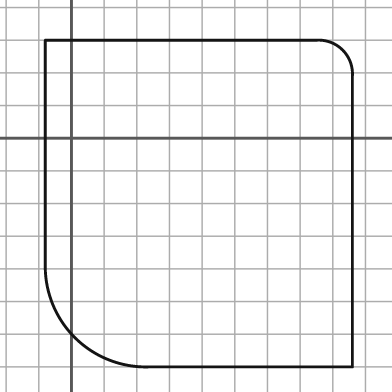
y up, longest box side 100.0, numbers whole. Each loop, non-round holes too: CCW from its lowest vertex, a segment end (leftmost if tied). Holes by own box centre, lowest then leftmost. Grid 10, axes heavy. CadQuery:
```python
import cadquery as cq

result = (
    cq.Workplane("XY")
    .moveTo(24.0, -70.0)
    .lineTo(86.0, -70.0)
    .lineTo(86.0, 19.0)
    .threePointArc((83.0, 27.0), (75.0, 30.0))
    .lineTo(-8.0, 30.0)
    .lineTo(-8.0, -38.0)
    .threePointArc((1.0, -61.0), (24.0, -70.0))
    .close()
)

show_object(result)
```